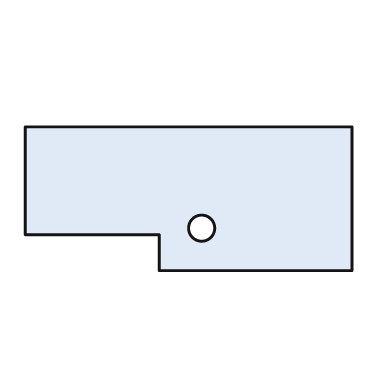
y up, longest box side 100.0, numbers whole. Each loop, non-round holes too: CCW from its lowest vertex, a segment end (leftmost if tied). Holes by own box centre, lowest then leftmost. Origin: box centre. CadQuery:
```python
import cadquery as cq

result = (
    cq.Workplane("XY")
    .moveTo(-9.0, -22.0)
    .lineTo(50.0, -22.0)
    .lineTo(50.0, 22.0)
    .lineTo(-50.0, 22.0)
    .lineTo(-50.0, -11.0)
    .lineTo(-9.0, -11.0)
    .close()
    .moveTo(4.0, -9.0)
    .circle(4.0)
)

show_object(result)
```